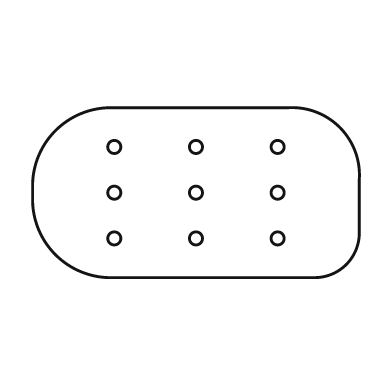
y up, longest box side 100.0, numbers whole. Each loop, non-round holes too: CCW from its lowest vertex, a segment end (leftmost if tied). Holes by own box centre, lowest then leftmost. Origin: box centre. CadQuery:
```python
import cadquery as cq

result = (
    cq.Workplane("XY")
    .moveTo(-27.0, -26.0)
    .lineTo(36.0, -26.0)
    .threePointArc((46.0, -22.0), (50.0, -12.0))
    .lineTo(50.0, 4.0)
    .threePointArc((44.0, 20.0), (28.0, 26.0))
    .lineTo(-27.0, 26.0)
    .threePointArc((-43.0, 19.0), (-50.0, 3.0))
    .lineTo(-50.0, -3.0)
    .threePointArc((-43.0, -19.0), (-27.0, -26.0))
    .close()
    .moveTo(-25.0, -14.0)
    .circle(2.0)
    .moveTo(0.0, -14.0)
    .circle(2.0)
    .moveTo(25.0, -14.0)
    .circle(2.0)
    .moveTo(-25.0, 0.0)
    .circle(2.0)
    .moveTo(0.0, 0.0)
    .circle(2.0)
    .moveTo(25.0, 0.0)
    .circle(2.0)
    .moveTo(-25.0, 14.0)
    .circle(2.0)
    .moveTo(0.0, 14.0)
    .circle(2.0)
    .moveTo(25.0, 14.0)
    .circle(2.0)
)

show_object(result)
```